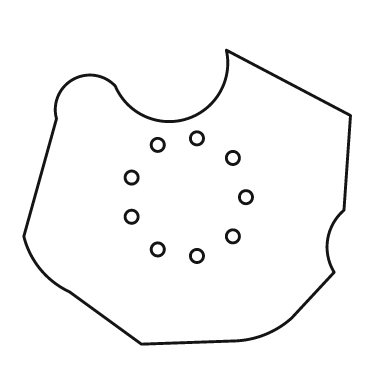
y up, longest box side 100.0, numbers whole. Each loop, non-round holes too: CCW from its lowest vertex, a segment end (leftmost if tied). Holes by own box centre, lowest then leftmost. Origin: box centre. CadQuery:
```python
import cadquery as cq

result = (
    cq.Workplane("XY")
    .moveTo(-14.0, -45.0)
    .lineTo(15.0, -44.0)
    .threePointArc((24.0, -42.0), (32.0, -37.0))
    .lineTo(45.0, -23.0)
    .threePointArc((43.0, -13.0), (48.0, -4.0))
    .lineTo(50.0, 25.0)
    .lineTo(12.0, 45.0)
    .threePointArc((0.0, 24.0), (-22.0, 34.0))
    .threePointArc((-35.0, 36.0), (-40.0, 24.0))
    .lineTo(-50.0, -12.0)
    .threePointArc((-45.0, -22.0), (-36.0, -29.0))
    .close()
    .moveTo(3.0, -18.0)
    .circle(2.0)
    .moveTo(-9.0, -16.0)
    .circle(2.0)
    .moveTo(14.0, -12.0)
    .circle(2.0)
    .moveTo(-17.0, -6.0)
    .circle(2.0)
    .moveTo(18.0, 0.0)
    .circle(2.0)
    .moveTo(-17.0, 6.0)
    .circle(2.0)
    .moveTo(14.0, 12.0)
    .circle(2.0)
    .moveTo(-9.0, 16.0)
    .circle(2.0)
    .moveTo(3.0, 18.0)
    .circle(2.0)
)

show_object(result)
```